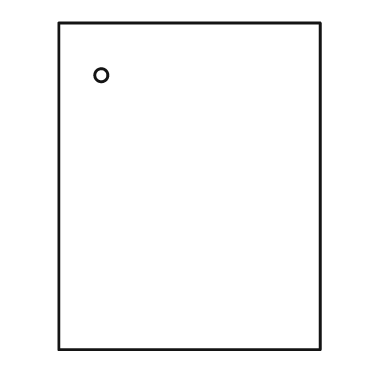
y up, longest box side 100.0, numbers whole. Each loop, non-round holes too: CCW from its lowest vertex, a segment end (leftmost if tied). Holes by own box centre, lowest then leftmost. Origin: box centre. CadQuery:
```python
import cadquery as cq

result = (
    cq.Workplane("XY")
    .moveTo(-40.0, -50.0)
    .lineTo(40.0, -50.0)
    .lineTo(40.0, 50.0)
    .lineTo(-40.0, 50.0)
    .close()
    .moveTo(-27.0, 34.0)
    .circle(2.0)
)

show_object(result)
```